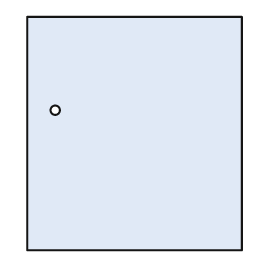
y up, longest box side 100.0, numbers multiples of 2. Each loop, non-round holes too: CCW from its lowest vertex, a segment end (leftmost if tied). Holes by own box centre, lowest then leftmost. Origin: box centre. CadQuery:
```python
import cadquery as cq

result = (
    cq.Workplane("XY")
    .moveTo(-46.0, -50.0)
    .lineTo(46.0, -50.0)
    .lineTo(46.0, 50.0)
    .lineTo(-46.0, 50.0)
    .close()
    .moveTo(-34.0, 10.0)
    .circle(2.0)
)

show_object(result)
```